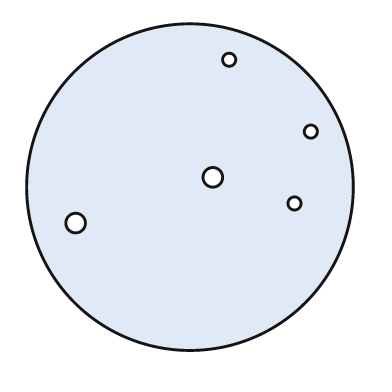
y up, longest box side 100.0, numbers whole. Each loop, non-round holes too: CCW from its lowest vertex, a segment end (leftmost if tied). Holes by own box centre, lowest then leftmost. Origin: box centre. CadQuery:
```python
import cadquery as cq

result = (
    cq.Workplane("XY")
    .moveTo(0.0, 0.0)
    .circle(50.0)
    .moveTo(-35.0, -11.0)
    .circle(3.0)
    .moveTo(32.0, -5.0)
    .circle(2.0)
    .moveTo(7.0, 3.0)
    .circle(3.0)
    .moveTo(37.0, 17.0)
    .circle(2.0)
    .moveTo(12.0, 39.0)
    .circle(2.0)
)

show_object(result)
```